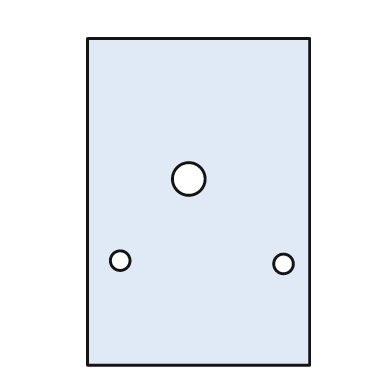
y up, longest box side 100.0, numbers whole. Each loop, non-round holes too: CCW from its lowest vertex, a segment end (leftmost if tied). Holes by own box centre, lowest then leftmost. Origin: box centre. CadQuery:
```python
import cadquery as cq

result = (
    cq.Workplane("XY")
    .moveTo(-34.0, -50.0)
    .lineTo(34.0, -50.0)
    .lineTo(34.0, 50.0)
    .lineTo(-34.0, 50.0)
    .close()
    .moveTo(26.0, -19.0)
    .circle(3.0)
    .moveTo(-24.0, -18.0)
    .circle(3.0)
    .moveTo(-3.0, 7.0)
    .circle(5.0)
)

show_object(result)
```